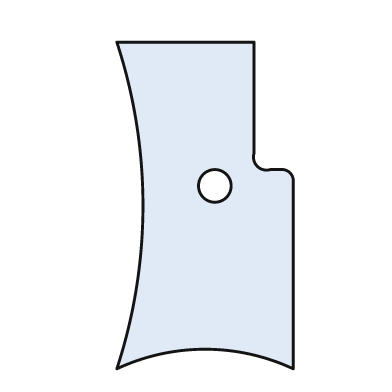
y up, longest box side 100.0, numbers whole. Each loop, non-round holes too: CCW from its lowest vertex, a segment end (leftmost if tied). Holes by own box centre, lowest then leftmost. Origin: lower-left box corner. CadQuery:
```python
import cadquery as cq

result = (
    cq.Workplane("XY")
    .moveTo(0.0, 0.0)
    .threePointArc((27.0, 6.0), (54.0, 0.0))
    .lineTo(54.0, 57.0)
    .threePointArc((53.0, 60.0), (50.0, 61.0))
    .lineTo(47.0, 61.0)
    .threePointArc((43.0, 62.0), (42.0, 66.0))
    .lineTo(42.0, 100.0)
    .lineTo(0.0, 100.0)
    .threePointArc((8.0, 50.0), (0.0, 0.0))
    .close()
    .moveTo(30.0, 56.0)
    .circle(5.0)
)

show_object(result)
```